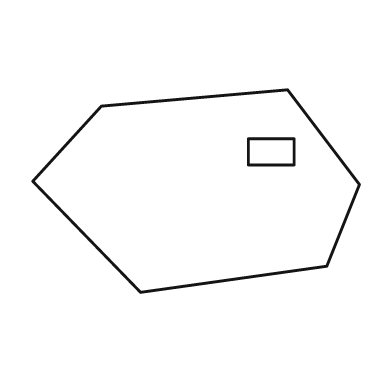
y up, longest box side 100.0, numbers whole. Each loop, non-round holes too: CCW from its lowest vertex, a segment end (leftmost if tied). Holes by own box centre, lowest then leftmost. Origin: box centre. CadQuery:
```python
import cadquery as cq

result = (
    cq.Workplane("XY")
    .moveTo(-17.0, -31.0)
    .lineTo(40.0, -23.0)
    .lineTo(50.0, 2.0)
    .lineTo(28.0, 31.0)
    .lineTo(-29.0, 26.0)
    .lineTo(-50.0, 3.0)
    .close()
    .moveTo(16.0, 8.0)
    .lineTo(30.0, 8.0)
    .lineTo(30.0, 16.0)
    .lineTo(16.0, 16.0)
    .close()
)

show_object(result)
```